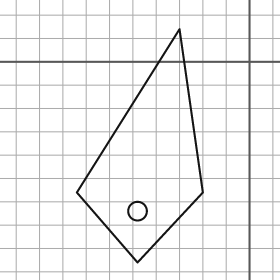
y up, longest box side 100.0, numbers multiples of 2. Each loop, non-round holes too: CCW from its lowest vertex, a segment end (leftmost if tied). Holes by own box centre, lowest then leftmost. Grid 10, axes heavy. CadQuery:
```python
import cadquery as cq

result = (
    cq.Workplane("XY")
    .moveTo(-48.0, -86.0)
    .lineTo(-20.0, -56.0)
    .lineTo(-30.0, 14.0)
    .lineTo(-74.0, -56.0)
    .close()
    .moveTo(-48.0, -64.0)
    .circle(4.0)
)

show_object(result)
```